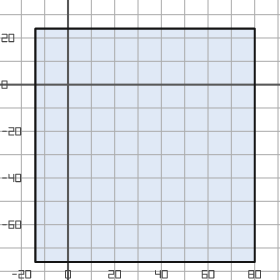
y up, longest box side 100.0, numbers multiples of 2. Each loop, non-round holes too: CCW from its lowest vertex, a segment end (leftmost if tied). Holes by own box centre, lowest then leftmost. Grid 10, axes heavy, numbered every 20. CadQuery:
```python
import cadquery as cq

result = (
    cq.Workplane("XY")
    .moveTo(-14.0, -76.0)
    .lineTo(80.0, -76.0)
    .lineTo(80.0, 24.0)
    .lineTo(-14.0, 24.0)
    .close()
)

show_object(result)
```